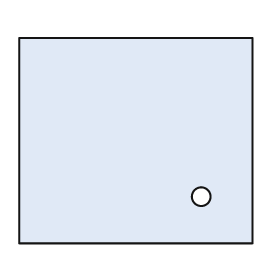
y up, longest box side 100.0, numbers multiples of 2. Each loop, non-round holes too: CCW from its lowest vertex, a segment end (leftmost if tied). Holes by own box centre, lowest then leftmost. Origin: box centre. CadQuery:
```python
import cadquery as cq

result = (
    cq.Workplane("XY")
    .moveTo(-50.0, -44.0)
    .lineTo(50.0, -44.0)
    .lineTo(50.0, 44.0)
    .lineTo(-50.0, 44.0)
    .close()
    .moveTo(28.0, -24.0)
    .circle(4.0)
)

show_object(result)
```